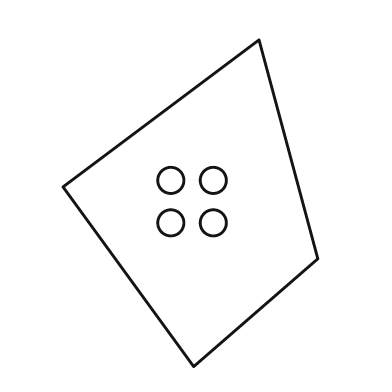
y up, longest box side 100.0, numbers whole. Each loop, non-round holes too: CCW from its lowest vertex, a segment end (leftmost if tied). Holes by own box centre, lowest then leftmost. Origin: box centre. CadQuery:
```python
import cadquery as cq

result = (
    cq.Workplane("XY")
    .moveTo(1.0, -50.0)
    .lineTo(39.0, -17.0)
    .lineTo(21.0, 50.0)
    .lineTo(-39.0, 5.0)
    .close()
    .moveTo(-6.0, -6.0)
    .circle(4.0)
    .moveTo(7.0, -6.0)
    .circle(4.0)
    .moveTo(-6.0, 7.0)
    .circle(4.0)
    .moveTo(7.0, 7.0)
    .circle(4.0)
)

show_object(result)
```